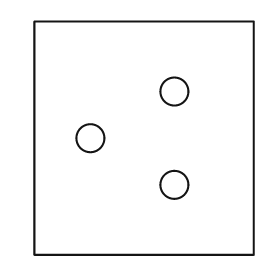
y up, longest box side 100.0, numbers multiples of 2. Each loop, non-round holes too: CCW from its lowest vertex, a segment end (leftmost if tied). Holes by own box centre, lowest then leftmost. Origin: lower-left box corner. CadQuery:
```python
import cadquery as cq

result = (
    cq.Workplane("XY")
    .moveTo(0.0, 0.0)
    .lineTo(94.0, 0.0)
    .lineTo(94.0, 100.0)
    .lineTo(0.0, 100.0)
    .close()
    .moveTo(60.0, 30.0)
    .circle(6.0)
    .moveTo(24.0, 50.0)
    .circle(6.0)
    .moveTo(60.0, 70.0)
    .circle(6.0)
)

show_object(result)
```